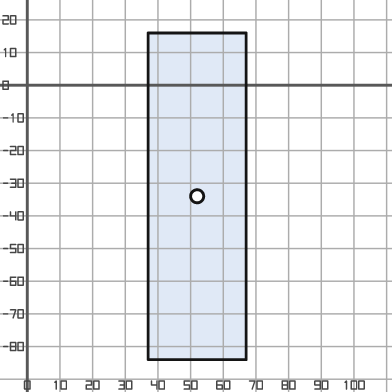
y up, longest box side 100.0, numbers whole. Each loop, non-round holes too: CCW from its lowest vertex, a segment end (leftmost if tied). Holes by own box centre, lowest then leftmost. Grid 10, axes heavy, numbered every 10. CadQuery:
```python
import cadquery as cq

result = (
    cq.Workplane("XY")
    .moveTo(37.0, -84.0)
    .lineTo(67.0, -84.0)
    .lineTo(67.0, 16.0)
    .lineTo(37.0, 16.0)
    .close()
    .moveTo(52.0, -34.0)
    .circle(2.0)
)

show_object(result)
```